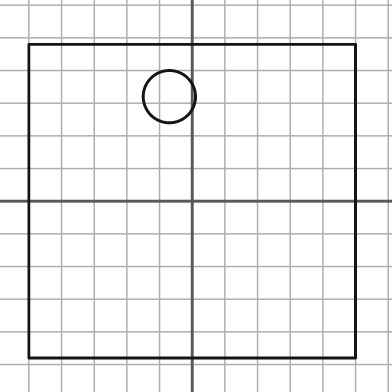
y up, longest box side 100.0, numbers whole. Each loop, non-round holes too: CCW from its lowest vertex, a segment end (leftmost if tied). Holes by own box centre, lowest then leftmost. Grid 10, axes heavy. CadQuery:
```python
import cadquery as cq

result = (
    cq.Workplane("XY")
    .moveTo(-50.0, -48.0)
    .lineTo(50.0, -48.0)
    .lineTo(50.0, 48.0)
    .lineTo(-50.0, 48.0)
    .close()
    .moveTo(-7.0, 32.0)
    .circle(8.0)
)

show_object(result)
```